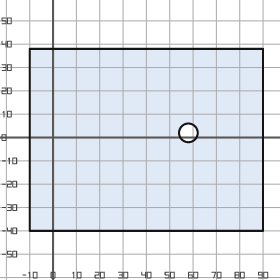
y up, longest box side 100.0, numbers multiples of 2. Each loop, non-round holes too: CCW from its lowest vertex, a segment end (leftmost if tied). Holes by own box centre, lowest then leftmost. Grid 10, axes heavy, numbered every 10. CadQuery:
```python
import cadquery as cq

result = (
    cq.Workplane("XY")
    .moveTo(-10.0, -40.0)
    .lineTo(90.0, -40.0)
    .lineTo(90.0, 38.0)
    .lineTo(-10.0, 38.0)
    .close()
    .moveTo(58.0, 2.0)
    .circle(4.0)
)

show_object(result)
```